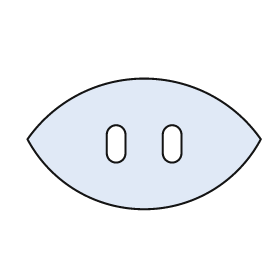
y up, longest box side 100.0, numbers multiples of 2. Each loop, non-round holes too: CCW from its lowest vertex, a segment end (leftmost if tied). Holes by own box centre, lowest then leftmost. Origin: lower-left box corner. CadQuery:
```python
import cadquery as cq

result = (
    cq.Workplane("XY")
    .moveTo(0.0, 30.0)
    .threePointArc((50.0, 0.0), (100.0, 30.0))
    .threePointArc((50.0, 56.0), (0.0, 30.0))
    .close()
    .moveTo(34.0, 24.0)
    .threePointArc((38.0, 20.0), (42.0, 24.0))
    .lineTo(42.0, 32.0)
    .threePointArc((38.0, 36.0), (34.0, 32.0))
    .close()
    .moveTo(58.0, 24.0)
    .threePointArc((62.0, 20.0), (66.0, 24.0))
    .lineTo(66.0, 32.0)
    .threePointArc((62.0, 36.0), (58.0, 32.0))
    .close()
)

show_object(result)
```